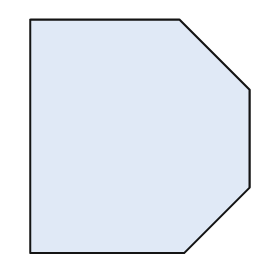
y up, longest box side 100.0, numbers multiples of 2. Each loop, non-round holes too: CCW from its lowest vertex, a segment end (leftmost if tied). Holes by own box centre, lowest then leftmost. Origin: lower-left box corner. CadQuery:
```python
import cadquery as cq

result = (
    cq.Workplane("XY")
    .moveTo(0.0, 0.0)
    .lineTo(66.0, 0.0)
    .lineTo(94.0, 28.0)
    .lineTo(94.0, 70.0)
    .lineTo(64.0, 100.0)
    .lineTo(0.0, 100.0)
    .close()
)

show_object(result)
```